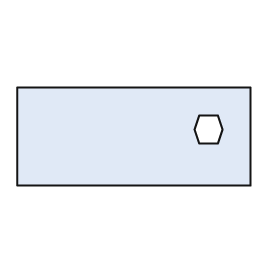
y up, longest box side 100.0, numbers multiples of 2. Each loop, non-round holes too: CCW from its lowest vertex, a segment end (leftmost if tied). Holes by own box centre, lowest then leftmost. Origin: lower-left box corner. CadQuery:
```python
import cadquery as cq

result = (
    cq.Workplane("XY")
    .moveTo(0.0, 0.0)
    .lineTo(100.0, 0.0)
    .lineTo(100.0, 42.0)
    .lineTo(0.0, 42.0)
    .close()
    .moveTo(78.0, 18.0)
    .lineTo(86.0, 18.0)
    .lineTo(88.0, 24.0)
    .lineTo(86.0, 30.0)
    .lineTo(78.0, 30.0)
    .lineTo(76.0, 24.0)
    .close()
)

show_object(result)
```